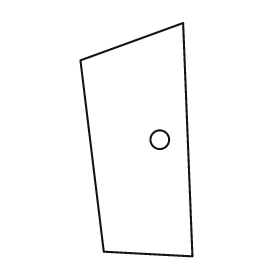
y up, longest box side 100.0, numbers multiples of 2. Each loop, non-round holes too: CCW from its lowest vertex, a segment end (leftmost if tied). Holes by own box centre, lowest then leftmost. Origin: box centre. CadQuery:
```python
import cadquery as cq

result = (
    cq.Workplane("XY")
    .moveTo(24.0, -50.0)
    .lineTo(20.0, 50.0)
    .lineTo(-24.0, 34.0)
    .lineTo(-14.0, -48.0)
    .close()
    .moveTo(10.0, 0.0)
    .circle(4.0)
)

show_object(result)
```